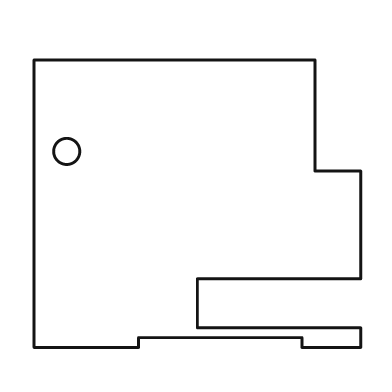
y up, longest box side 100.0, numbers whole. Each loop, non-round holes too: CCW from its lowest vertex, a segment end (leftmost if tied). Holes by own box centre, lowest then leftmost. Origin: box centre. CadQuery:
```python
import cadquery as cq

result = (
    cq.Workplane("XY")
    .moveTo(-50.0, -44.0)
    .lineTo(-18.0, -44.0)
    .lineTo(-18.0, -41.0)
    .lineTo(32.0, -41.0)
    .lineTo(32.0, -44.0)
    .lineTo(50.0, -44.0)
    .lineTo(50.0, -38.0)
    .lineTo(0.0, -38.0)
    .lineTo(0.0, -23.0)
    .lineTo(50.0, -23.0)
    .lineTo(50.0, 10.0)
    .lineTo(36.0, 10.0)
    .lineTo(36.0, 44.0)
    .lineTo(-50.0, 44.0)
    .close()
    .moveTo(-40.0, 16.0)
    .circle(4.0)
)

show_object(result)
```